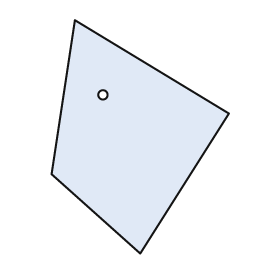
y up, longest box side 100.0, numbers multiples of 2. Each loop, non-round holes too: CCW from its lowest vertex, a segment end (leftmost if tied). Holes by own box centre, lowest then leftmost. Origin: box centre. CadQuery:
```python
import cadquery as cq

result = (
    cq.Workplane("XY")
    .moveTo(0.0, -50.0)
    .lineTo(38.0, 10.0)
    .lineTo(-28.0, 50.0)
    .lineTo(-38.0, -16.0)
    .close()
    .moveTo(-16.0, 18.0)
    .circle(2.0)
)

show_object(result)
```